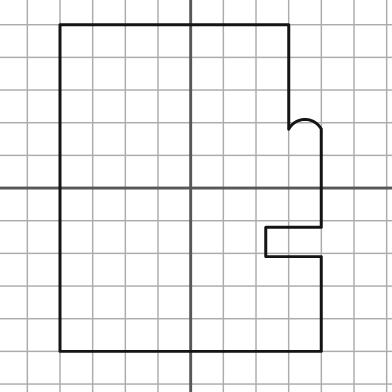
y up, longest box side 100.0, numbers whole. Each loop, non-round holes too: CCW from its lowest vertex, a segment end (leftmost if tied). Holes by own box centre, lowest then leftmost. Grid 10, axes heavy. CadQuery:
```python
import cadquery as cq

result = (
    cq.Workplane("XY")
    .moveTo(-40.0, -50.0)
    .lineTo(40.0, -50.0)
    .lineTo(40.0, -21.0)
    .lineTo(23.0, -21.0)
    .lineTo(23.0, -12.0)
    .lineTo(40.0, -12.0)
    .lineTo(40.0, 18.0)
    .threePointArc((35.0, 21.0), (30.0, 18.0))
    .lineTo(30.0, 50.0)
    .lineTo(-40.0, 50.0)
    .close()
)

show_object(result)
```